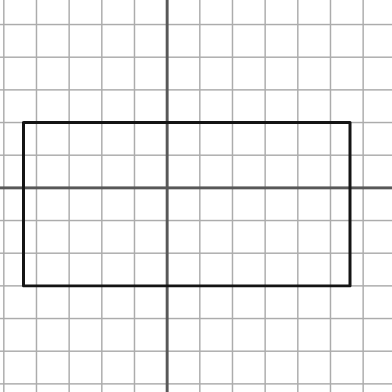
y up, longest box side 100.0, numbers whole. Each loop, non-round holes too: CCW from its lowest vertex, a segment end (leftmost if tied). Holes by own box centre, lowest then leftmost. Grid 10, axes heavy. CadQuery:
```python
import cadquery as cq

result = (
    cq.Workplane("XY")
    .moveTo(-44.0, -30.0)
    .lineTo(56.0, -30.0)
    .lineTo(56.0, 20.0)
    .lineTo(-44.0, 20.0)
    .close()
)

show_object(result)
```